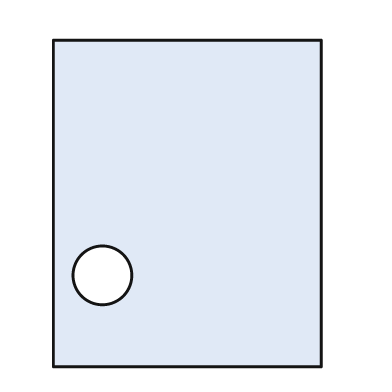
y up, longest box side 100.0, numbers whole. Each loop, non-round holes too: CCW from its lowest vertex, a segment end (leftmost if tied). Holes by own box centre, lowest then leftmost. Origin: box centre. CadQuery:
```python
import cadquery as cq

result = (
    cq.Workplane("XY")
    .moveTo(-41.0, -50.0)
    .lineTo(41.0, -50.0)
    .lineTo(41.0, 50.0)
    .lineTo(-41.0, 50.0)
    .close()
    .moveTo(-26.0, -22.0)
    .circle(9.0)
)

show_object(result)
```